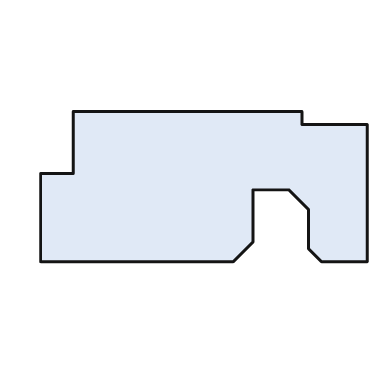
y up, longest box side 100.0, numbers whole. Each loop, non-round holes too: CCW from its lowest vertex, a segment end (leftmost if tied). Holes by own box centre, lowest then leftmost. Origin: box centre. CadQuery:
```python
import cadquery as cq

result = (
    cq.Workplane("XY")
    .moveTo(-50.0, -23.0)
    .lineTo(9.0, -23.0)
    .lineTo(15.0, -17.0)
    .lineTo(15.0, -1.0)
    .lineTo(26.0, -1.0)
    .lineTo(32.0, -7.0)
    .lineTo(32.0, -19.0)
    .lineTo(36.0, -23.0)
    .lineTo(50.0, -23.0)
    .lineTo(50.0, 19.0)
    .lineTo(30.0, 19.0)
    .lineTo(30.0, 23.0)
    .lineTo(-40.0, 23.0)
    .lineTo(-40.0, 4.0)
    .lineTo(-50.0, 4.0)
    .close()
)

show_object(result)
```